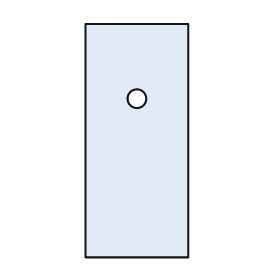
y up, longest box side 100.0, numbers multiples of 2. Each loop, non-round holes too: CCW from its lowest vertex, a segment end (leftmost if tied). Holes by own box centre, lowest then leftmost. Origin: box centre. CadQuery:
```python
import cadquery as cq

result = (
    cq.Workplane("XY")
    .moveTo(-22.0, -50.0)
    .lineTo(22.0, -50.0)
    .lineTo(22.0, 50.0)
    .lineTo(-22.0, 50.0)
    .close()
    .moveTo(0.0, 18.0)
    .circle(4.0)
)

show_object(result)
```